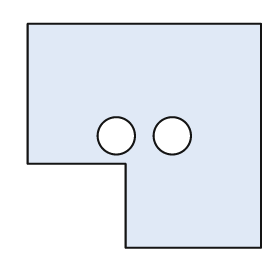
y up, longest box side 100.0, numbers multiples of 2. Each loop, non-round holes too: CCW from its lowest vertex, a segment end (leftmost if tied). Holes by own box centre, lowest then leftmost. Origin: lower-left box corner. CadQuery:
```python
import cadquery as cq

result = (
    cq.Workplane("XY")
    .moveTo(42.0, 0.0)
    .lineTo(100.0, 0.0)
    .lineTo(100.0, 96.0)
    .lineTo(0.0, 96.0)
    .lineTo(0.0, 36.0)
    .lineTo(42.0, 36.0)
    .close()
    .moveTo(38.0, 48.0)
    .circle(8.0)
    .moveTo(62.0, 48.0)
    .circle(8.0)
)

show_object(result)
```